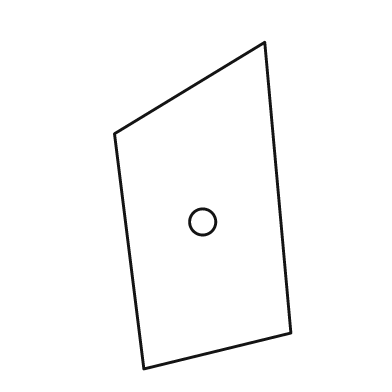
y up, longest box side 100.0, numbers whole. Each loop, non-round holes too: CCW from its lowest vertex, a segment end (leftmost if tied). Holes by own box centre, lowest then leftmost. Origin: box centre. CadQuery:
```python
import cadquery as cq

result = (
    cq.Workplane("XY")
    .moveTo(-18.0, -50.0)
    .lineTo(27.0, -39.0)
    .lineTo(19.0, 50.0)
    .lineTo(-27.0, 22.0)
    .close()
    .moveTo(0.0, -5.0)
    .circle(4.0)
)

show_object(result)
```